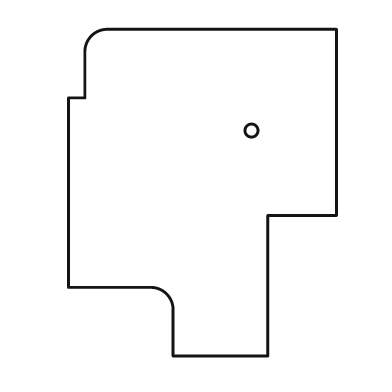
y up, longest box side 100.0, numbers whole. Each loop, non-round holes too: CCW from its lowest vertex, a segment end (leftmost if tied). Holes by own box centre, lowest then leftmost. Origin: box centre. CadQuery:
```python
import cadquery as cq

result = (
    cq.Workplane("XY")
    .moveTo(-9.0, -50.0)
    .lineTo(20.0, -50.0)
    .lineTo(20.0, -7.0)
    .lineTo(41.0, -7.0)
    .lineTo(41.0, 50.0)
    .lineTo(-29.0, 50.0)
    .threePointArc((-34.0, 48.0), (-36.0, 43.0))
    .lineTo(-36.0, 29.0)
    .lineTo(-41.0, 29.0)
    .lineTo(-41.0, -29.0)
    .lineTo(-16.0, -29.0)
    .threePointArc((-11.0, -31.0), (-9.0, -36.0))
    .close()
    .moveTo(15.0, 19.0)
    .circle(2.0)
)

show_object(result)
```